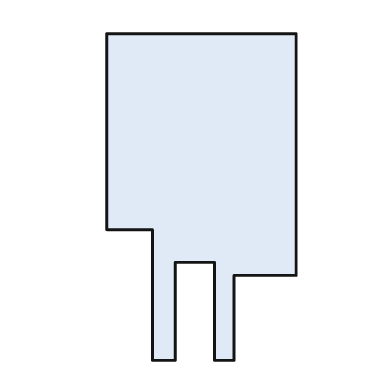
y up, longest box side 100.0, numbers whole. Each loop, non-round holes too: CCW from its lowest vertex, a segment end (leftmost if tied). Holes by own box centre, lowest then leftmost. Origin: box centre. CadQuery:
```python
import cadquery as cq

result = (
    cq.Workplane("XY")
    .moveTo(-15.0, -50.0)
    .lineTo(-8.0, -50.0)
    .lineTo(-8.0, -20.0)
    .lineTo(4.0, -20.0)
    .lineTo(4.0, -50.0)
    .lineTo(10.0, -50.0)
    .lineTo(10.0, -24.0)
    .lineTo(29.0, -24.0)
    .lineTo(29.0, 50.0)
    .lineTo(-29.0, 50.0)
    .lineTo(-29.0, -10.0)
    .lineTo(-15.0, -10.0)
    .close()
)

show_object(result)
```